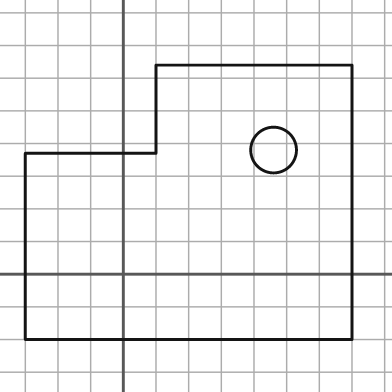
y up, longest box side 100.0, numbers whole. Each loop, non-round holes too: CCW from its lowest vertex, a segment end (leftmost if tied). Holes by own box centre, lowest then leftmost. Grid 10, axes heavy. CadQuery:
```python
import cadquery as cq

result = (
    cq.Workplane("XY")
    .moveTo(-30.0, -20.0)
    .lineTo(70.0, -20.0)
    .lineTo(70.0, 64.0)
    .lineTo(10.0, 64.0)
    .lineTo(10.0, 37.0)
    .lineTo(-30.0, 37.0)
    .close()
    .moveTo(46.0, 38.0)
    .circle(7.0)
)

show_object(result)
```